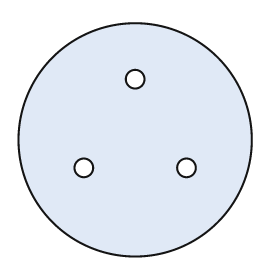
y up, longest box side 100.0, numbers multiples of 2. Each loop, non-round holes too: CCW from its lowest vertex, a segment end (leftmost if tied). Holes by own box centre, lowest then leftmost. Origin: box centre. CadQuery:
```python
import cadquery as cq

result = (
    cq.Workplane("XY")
    .moveTo(0.0, 0.0)
    .circle(50.0)
    .moveTo(-22.0, -12.0)
    .circle(4.0)
    .moveTo(22.0, -12.0)
    .circle(4.0)
    .moveTo(0.0, 26.0)
    .circle(4.0)
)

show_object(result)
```